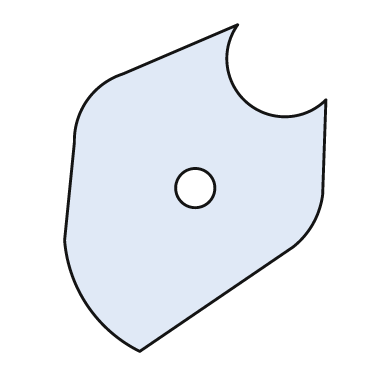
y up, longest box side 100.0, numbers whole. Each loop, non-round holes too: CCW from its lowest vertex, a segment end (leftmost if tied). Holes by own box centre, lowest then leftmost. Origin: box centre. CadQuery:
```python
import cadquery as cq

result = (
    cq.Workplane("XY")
    .moveTo(-17.0, -50.0)
    .lineTo(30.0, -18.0)
    .threePointArc((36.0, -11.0), (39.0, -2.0))
    .lineTo(40.0, 27.0)
    .threePointArc((16.0, 26.0), (13.0, 50.0))
    .lineTo(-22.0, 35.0)
    .threePointArc((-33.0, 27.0), (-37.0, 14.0))
    .lineTo(-40.0, -16.0)
    .threePointArc((-33.0, -36.0), (-17.0, -50.0))
    .close()
    .moveTo(0.0, 0.0)
    .circle(6.0)
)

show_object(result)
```